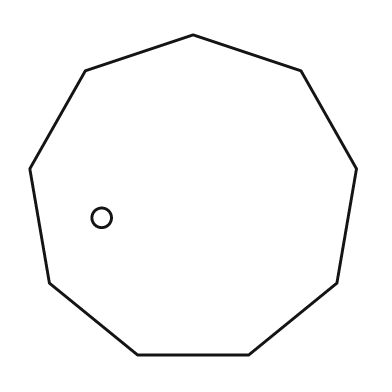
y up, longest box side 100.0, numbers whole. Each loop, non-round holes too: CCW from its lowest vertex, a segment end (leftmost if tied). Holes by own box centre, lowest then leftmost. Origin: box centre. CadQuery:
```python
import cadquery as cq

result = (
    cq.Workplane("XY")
    .moveTo(-17.0, -49.0)
    .lineTo(17.0, -49.0)
    .lineTo(44.0, -27.0)
    .lineTo(50.0, 8.0)
    .lineTo(33.0, 38.0)
    .lineTo(0.0, 49.0)
    .lineTo(-33.0, 38.0)
    .lineTo(-50.0, 8.0)
    .lineTo(-44.0, -27.0)
    .close()
    .moveTo(-28.0, -7.0)
    .circle(3.0)
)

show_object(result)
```